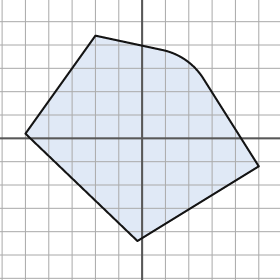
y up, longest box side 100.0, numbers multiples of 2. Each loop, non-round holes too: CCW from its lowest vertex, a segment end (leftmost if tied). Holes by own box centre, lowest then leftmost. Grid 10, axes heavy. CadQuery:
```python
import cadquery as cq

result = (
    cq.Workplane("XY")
    .moveTo(-2.0, -44.0)
    .lineTo(50.0, -12.0)
    .lineTo(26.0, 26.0)
    .threePointArc((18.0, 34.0), (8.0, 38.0))
    .lineTo(-20.0, 44.0)
    .lineTo(-50.0, 2.0)
    .close()
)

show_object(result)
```